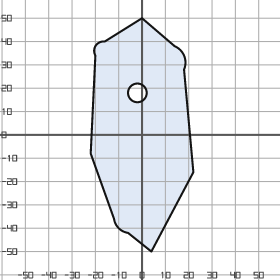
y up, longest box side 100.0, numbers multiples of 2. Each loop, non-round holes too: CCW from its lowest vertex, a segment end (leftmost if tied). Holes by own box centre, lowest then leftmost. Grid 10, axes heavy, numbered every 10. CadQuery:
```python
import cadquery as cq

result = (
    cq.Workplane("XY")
    .moveTo(4.0, -50.0)
    .lineTo(22.0, -16.0)
    .lineTo(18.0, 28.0)
    .threePointArc((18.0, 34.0), (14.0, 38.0))
    .lineTo(0.0, 50.0)
    .lineTo(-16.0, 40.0)
    .threePointArc((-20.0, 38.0), (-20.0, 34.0))
    .lineTo(-22.0, -8.0)
    .lineTo(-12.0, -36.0)
    .threePointArc((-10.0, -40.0), (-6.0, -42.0))
    .close()
    .moveTo(-2.0, 18.0)
    .circle(4.0)
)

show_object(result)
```